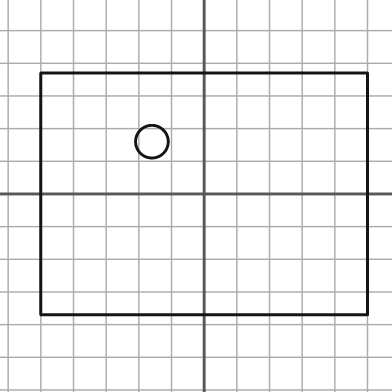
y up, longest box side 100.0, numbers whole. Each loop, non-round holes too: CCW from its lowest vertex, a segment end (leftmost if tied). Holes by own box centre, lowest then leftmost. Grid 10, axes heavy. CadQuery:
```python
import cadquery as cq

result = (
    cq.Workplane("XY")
    .moveTo(-50.0, -37.0)
    .lineTo(50.0, -37.0)
    .lineTo(50.0, 37.0)
    .lineTo(-50.0, 37.0)
    .close()
    .moveTo(-16.0, 16.0)
    .circle(5.0)
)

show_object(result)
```